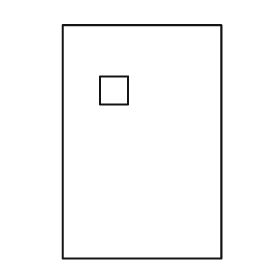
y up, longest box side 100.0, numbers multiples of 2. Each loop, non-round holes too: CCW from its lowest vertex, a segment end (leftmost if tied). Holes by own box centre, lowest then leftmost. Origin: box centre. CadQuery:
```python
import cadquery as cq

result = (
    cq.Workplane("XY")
    .moveTo(-34.0, -50.0)
    .lineTo(34.0, -50.0)
    .lineTo(34.0, 50.0)
    .lineTo(-34.0, 50.0)
    .close()
    .moveTo(-18.0, 16.0)
    .lineTo(-6.0, 16.0)
    .lineTo(-6.0, 28.0)
    .lineTo(-18.0, 28.0)
    .close()
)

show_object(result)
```